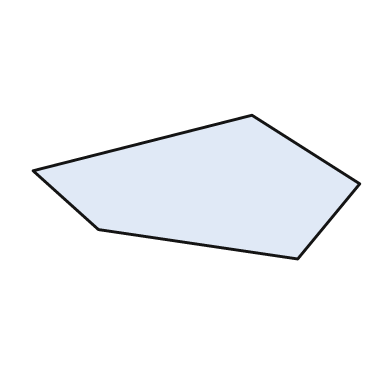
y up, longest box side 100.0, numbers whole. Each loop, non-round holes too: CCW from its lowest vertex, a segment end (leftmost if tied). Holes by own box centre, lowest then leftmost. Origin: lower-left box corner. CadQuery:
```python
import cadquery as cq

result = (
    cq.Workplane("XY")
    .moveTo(81.0, 0.0)
    .lineTo(100.0, 23.0)
    .lineTo(67.0, 44.0)
    .lineTo(0.0, 27.0)
    .lineTo(20.0, 9.0)
    .close()
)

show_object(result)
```